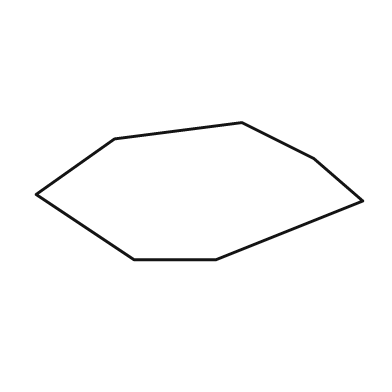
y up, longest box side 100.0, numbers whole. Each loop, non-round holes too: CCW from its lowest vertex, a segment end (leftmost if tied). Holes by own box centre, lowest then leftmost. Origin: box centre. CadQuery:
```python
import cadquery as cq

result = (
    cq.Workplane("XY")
    .moveTo(-20.0, -21.0)
    .lineTo(5.0, -21.0)
    .lineTo(50.0, -3.0)
    .lineTo(35.0, 10.0)
    .lineTo(13.0, 21.0)
    .lineTo(-26.0, 16.0)
    .lineTo(-50.0, -1.0)
    .close()
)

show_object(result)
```